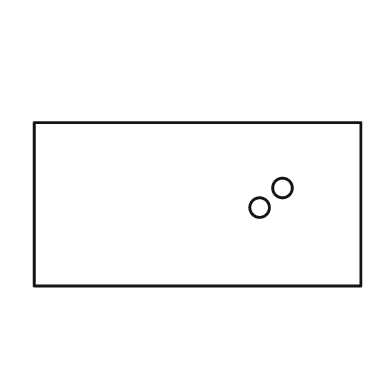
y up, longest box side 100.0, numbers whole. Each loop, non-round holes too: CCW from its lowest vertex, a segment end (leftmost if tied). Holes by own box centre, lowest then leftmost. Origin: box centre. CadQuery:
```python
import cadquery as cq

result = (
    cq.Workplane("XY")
    .moveTo(-50.0, -25.0)
    .lineTo(50.0, -25.0)
    .lineTo(50.0, 25.0)
    .lineTo(-50.0, 25.0)
    .close()
    .moveTo(19.0, -1.0)
    .circle(3.0)
    .moveTo(26.0, 5.0)
    .circle(3.0)
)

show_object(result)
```